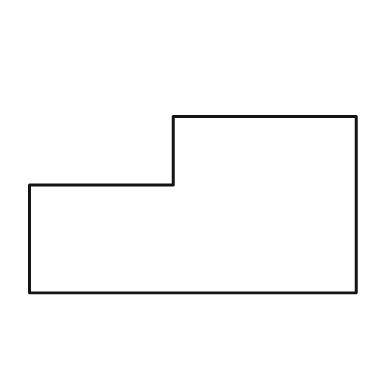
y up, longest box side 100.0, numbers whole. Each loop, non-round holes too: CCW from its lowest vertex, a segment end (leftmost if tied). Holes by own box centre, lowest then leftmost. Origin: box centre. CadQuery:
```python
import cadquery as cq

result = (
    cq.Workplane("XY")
    .moveTo(-50.0, -27.0)
    .lineTo(50.0, -27.0)
    .lineTo(50.0, 27.0)
    .lineTo(-6.0, 27.0)
    .lineTo(-6.0, 6.0)
    .lineTo(-50.0, 6.0)
    .close()
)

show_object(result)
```